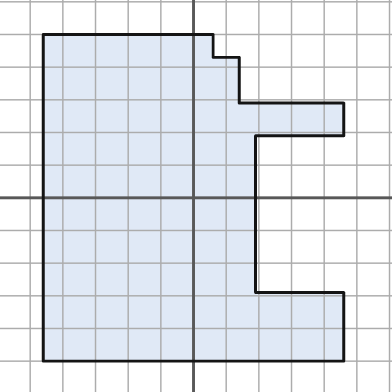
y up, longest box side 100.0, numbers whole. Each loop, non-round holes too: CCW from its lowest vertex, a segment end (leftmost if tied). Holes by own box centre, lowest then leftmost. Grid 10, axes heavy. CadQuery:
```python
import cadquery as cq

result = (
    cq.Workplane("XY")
    .moveTo(-46.0, -50.0)
    .lineTo(46.0, -50.0)
    .lineTo(46.0, -29.0)
    .lineTo(19.0, -29.0)
    .lineTo(19.0, 19.0)
    .lineTo(46.0, 19.0)
    .lineTo(46.0, 29.0)
    .lineTo(14.0, 29.0)
    .lineTo(14.0, 43.0)
    .lineTo(6.0, 43.0)
    .lineTo(6.0, 50.0)
    .lineTo(-46.0, 50.0)
    .close()
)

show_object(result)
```